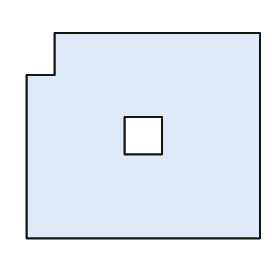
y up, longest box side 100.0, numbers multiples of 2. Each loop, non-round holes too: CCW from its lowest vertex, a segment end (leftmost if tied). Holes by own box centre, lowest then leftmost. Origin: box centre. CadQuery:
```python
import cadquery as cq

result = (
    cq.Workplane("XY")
    .moveTo(-50.0, -44.0)
    .lineTo(50.0, -44.0)
    .lineTo(50.0, 44.0)
    .lineTo(-38.0, 44.0)
    .lineTo(-38.0, 26.0)
    .lineTo(-50.0, 26.0)
    .close()
    .moveTo(-8.0, -8.0)
    .lineTo(8.0, -8.0)
    .lineTo(8.0, 8.0)
    .lineTo(-8.0, 8.0)
    .close()
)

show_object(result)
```